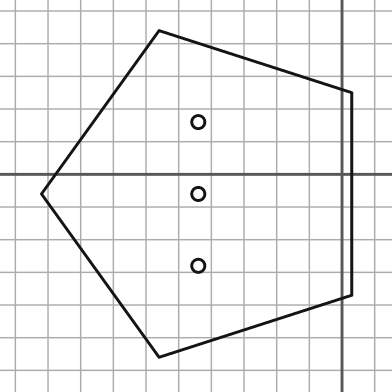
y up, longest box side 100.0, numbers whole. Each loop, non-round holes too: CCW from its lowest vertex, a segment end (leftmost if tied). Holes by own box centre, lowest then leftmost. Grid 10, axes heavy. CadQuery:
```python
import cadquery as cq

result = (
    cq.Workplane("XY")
    .moveTo(-56.0, -56.0)
    .lineTo(3.0, -37.0)
    .lineTo(3.0, 25.0)
    .lineTo(-56.0, 44.0)
    .lineTo(-92.0, -6.0)
    .close()
    .moveTo(-44.0, -28.0)
    .circle(2.0)
    .moveTo(-44.0, -6.0)
    .circle(2.0)
    .moveTo(-44.0, 16.0)
    .circle(2.0)
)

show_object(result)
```